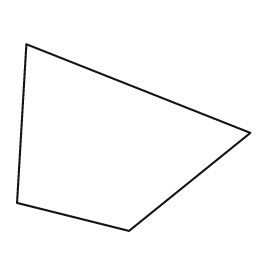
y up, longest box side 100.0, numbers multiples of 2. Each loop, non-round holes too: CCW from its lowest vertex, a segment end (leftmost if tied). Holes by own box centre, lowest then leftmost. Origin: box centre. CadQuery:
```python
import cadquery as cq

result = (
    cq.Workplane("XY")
    .moveTo(-2.0, -40.0)
    .lineTo(50.0, 2.0)
    .lineTo(-46.0, 40.0)
    .lineTo(-50.0, -28.0)
    .close()
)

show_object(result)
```